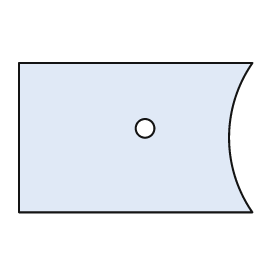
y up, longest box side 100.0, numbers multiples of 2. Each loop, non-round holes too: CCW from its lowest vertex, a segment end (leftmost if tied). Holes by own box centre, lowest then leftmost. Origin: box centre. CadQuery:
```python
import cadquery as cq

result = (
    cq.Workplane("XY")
    .moveTo(-50.0, -32.0)
    .lineTo(50.0, -32.0)
    .threePointArc((40.0, 0.0), (50.0, 32.0))
    .lineTo(-50.0, 32.0)
    .close()
    .moveTo(4.0, 4.0)
    .circle(4.0)
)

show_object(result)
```